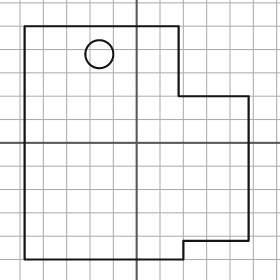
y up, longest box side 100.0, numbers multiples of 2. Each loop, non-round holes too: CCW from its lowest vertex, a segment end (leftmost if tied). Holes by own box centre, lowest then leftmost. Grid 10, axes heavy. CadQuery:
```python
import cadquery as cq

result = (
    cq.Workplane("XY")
    .moveTo(-48.0, -50.0)
    .lineTo(20.0, -50.0)
    .lineTo(20.0, -42.0)
    .lineTo(48.0, -42.0)
    .lineTo(48.0, 20.0)
    .lineTo(18.0, 20.0)
    .lineTo(18.0, 50.0)
    .lineTo(-48.0, 50.0)
    .close()
    .moveTo(-16.0, 38.0)
    .circle(6.0)
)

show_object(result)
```